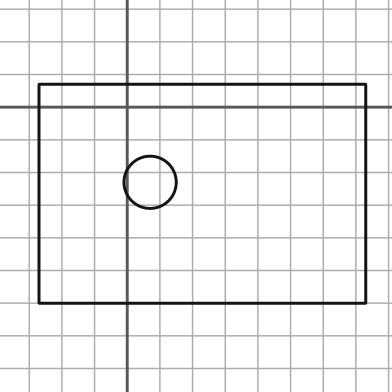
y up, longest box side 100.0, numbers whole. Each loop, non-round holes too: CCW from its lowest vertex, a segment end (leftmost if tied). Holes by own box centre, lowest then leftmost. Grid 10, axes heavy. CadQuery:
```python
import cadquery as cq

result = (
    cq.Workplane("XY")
    .moveTo(-27.0, -60.0)
    .lineTo(73.0, -60.0)
    .lineTo(73.0, 7.0)
    .lineTo(-27.0, 7.0)
    .close()
    .moveTo(7.0, -23.0)
    .circle(8.0)
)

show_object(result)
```